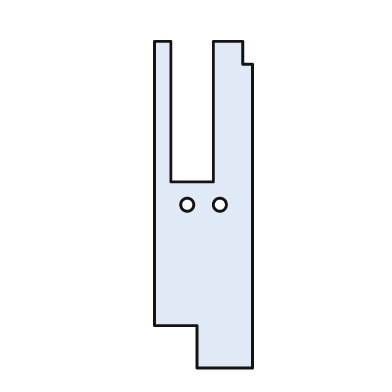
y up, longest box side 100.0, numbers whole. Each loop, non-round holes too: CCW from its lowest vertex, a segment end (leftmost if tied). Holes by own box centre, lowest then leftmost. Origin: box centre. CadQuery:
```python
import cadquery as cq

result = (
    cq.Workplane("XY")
    .moveTo(-2.0, -50.0)
    .lineTo(15.0, -50.0)
    .lineTo(15.0, 43.0)
    .lineTo(12.0, 43.0)
    .lineTo(12.0, 50.0)
    .lineTo(3.0, 50.0)
    .lineTo(3.0, 7.0)
    .lineTo(-10.0, 7.0)
    .lineTo(-10.0, 50.0)
    .lineTo(-15.0, 50.0)
    .lineTo(-15.0, -37.0)
    .lineTo(-2.0, -37.0)
    .close()
    .moveTo(-5.0, 0.0)
    .circle(2.0)
    .moveTo(5.0, 0.0)
    .circle(2.0)
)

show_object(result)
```